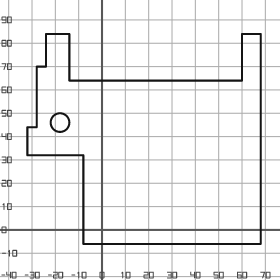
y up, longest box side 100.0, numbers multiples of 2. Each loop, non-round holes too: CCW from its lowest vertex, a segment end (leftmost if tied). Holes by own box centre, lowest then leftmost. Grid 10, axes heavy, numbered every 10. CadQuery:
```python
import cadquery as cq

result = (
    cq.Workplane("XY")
    .moveTo(-8.0, -6.0)
    .lineTo(68.0, -6.0)
    .lineTo(68.0, 84.0)
    .lineTo(60.0, 84.0)
    .lineTo(60.0, 64.0)
    .lineTo(-14.0, 64.0)
    .lineTo(-14.0, 84.0)
    .lineTo(-24.0, 84.0)
    .lineTo(-24.0, 70.0)
    .lineTo(-28.0, 70.0)
    .lineTo(-28.0, 44.0)
    .lineTo(-32.0, 44.0)
    .lineTo(-32.0, 32.0)
    .lineTo(-8.0, 32.0)
    .close()
    .moveTo(-18.0, 46.0)
    .circle(4.0)
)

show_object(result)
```